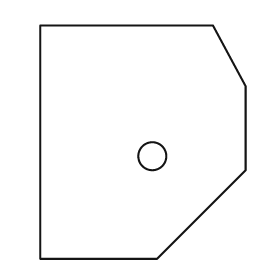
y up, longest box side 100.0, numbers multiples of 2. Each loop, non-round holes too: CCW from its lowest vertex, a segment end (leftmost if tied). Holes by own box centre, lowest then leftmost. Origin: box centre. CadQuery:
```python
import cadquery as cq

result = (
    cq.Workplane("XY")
    .moveTo(-44.0, -50.0)
    .lineTo(6.0, -50.0)
    .lineTo(44.0, -12.0)
    .lineTo(44.0, 24.0)
    .lineTo(30.0, 50.0)
    .lineTo(-44.0, 50.0)
    .close()
    .moveTo(4.0, -6.0)
    .circle(6.0)
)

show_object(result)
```